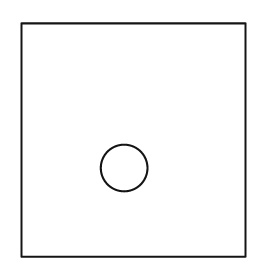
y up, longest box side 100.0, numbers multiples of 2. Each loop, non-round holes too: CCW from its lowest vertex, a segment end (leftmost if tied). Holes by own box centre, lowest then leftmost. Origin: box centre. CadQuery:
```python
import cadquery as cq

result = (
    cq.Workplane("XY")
    .moveTo(-48.0, -50.0)
    .lineTo(48.0, -50.0)
    .lineTo(48.0, 50.0)
    .lineTo(-48.0, 50.0)
    .close()
    .moveTo(-4.0, -12.0)
    .circle(10.0)
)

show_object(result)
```